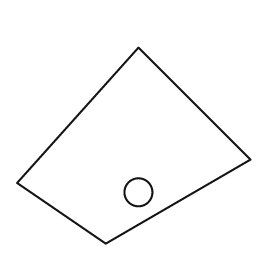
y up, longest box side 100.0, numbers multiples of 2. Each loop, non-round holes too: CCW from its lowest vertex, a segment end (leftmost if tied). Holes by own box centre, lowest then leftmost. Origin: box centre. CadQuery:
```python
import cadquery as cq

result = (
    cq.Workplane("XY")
    .moveTo(-12.0, -42.0)
    .lineTo(50.0, -6.0)
    .lineTo(2.0, 42.0)
    .lineTo(-50.0, -16.0)
    .close()
    .moveTo(2.0, -20.0)
    .circle(6.0)
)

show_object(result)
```